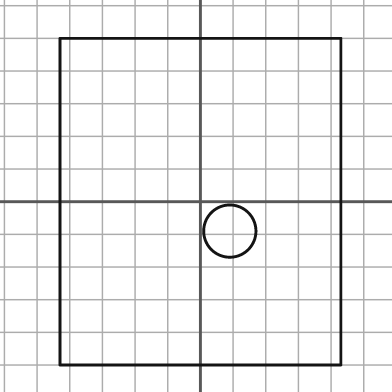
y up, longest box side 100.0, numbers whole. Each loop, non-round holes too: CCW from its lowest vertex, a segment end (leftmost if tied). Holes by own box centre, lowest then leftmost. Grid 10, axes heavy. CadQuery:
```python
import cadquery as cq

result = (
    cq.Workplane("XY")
    .moveTo(-43.0, -50.0)
    .lineTo(43.0, -50.0)
    .lineTo(43.0, 50.0)
    .lineTo(-43.0, 50.0)
    .close()
    .moveTo(9.0, -9.0)
    .circle(8.0)
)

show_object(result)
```